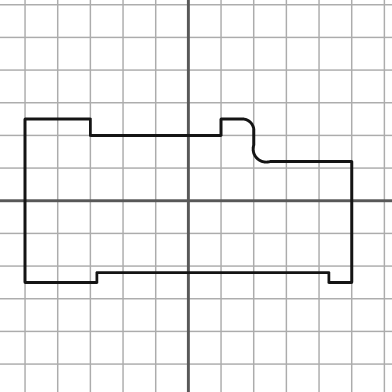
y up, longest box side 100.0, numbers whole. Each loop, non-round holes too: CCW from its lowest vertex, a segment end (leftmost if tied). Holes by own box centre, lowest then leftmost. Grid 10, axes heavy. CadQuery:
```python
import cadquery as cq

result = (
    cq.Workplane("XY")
    .moveTo(-50.0, -25.0)
    .lineTo(-28.0, -25.0)
    .lineTo(-28.0, -22.0)
    .lineTo(43.0, -22.0)
    .lineTo(43.0, -25.0)
    .lineTo(50.0, -25.0)
    .lineTo(50.0, 12.0)
    .lineTo(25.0, 12.0)
    .threePointArc((21.0, 13.0), (20.0, 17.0))
    .lineTo(20.0, 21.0)
    .threePointArc((19.0, 24.0), (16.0, 25.0))
    .lineTo(10.0, 25.0)
    .lineTo(10.0, 20.0)
    .lineTo(-30.0, 20.0)
    .lineTo(-30.0, 25.0)
    .lineTo(-50.0, 25.0)
    .close()
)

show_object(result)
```